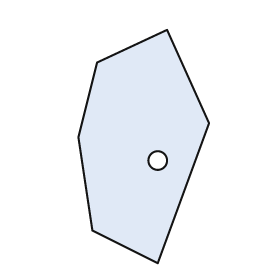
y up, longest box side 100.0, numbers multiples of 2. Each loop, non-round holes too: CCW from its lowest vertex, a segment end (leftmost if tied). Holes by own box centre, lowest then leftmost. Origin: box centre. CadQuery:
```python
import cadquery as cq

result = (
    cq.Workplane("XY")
    .moveTo(6.0, -50.0)
    .lineTo(28.0, 10.0)
    .lineTo(10.0, 50.0)
    .lineTo(-20.0, 36.0)
    .lineTo(-28.0, 4.0)
    .lineTo(-22.0, -36.0)
    .close()
    .moveTo(6.0, -6.0)
    .circle(4.0)
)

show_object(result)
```